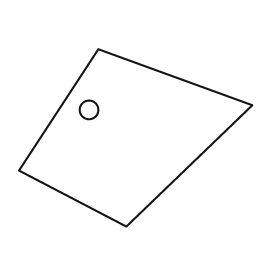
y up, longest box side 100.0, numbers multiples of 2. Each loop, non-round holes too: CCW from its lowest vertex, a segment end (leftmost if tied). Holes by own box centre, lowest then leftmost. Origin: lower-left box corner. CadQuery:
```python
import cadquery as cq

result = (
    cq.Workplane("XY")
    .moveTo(46.0, 0.0)
    .lineTo(100.0, 52.0)
    .lineTo(34.0, 76.0)
    .lineTo(0.0, 24.0)
    .close()
    .moveTo(30.0, 50.0)
    .circle(4.0)
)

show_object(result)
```